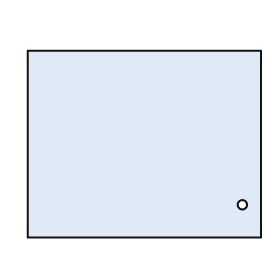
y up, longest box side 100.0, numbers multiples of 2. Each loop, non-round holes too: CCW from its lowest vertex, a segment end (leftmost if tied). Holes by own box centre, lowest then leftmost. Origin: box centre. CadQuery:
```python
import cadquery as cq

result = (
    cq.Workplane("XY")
    .moveTo(-50.0, -40.0)
    .lineTo(50.0, -40.0)
    .lineTo(50.0, 40.0)
    .lineTo(-50.0, 40.0)
    .close()
    .moveTo(42.0, -26.0)
    .circle(2.0)
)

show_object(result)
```